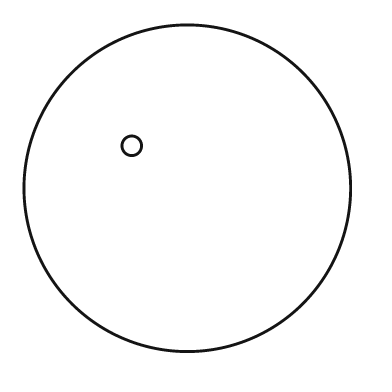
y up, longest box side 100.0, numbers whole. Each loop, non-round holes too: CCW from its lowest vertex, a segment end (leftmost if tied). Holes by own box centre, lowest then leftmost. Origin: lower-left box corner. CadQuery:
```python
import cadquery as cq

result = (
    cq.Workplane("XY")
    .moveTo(50.0, 50.0)
    .circle(50.0)
    .moveTo(33.0, 63.0)
    .circle(3.0)
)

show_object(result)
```